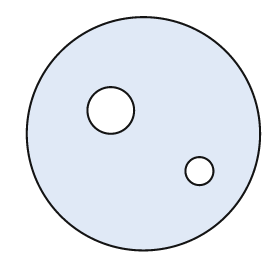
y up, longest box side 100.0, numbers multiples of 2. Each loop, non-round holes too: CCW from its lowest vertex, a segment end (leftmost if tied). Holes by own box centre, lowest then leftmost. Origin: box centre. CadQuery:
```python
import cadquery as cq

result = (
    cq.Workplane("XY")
    .moveTo(0.0, 0.0)
    .circle(50.0)
    .moveTo(24.0, -16.0)
    .circle(6.0)
    .moveTo(-14.0, 10.0)
    .circle(10.0)
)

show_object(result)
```